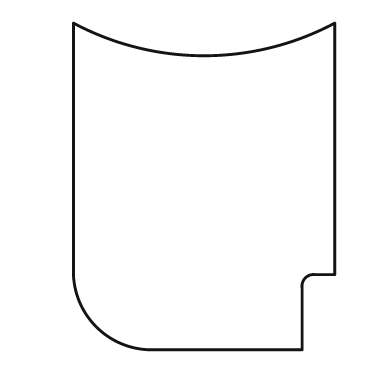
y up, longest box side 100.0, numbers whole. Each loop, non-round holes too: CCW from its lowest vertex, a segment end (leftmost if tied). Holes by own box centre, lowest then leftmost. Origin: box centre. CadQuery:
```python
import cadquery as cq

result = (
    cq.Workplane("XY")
    .moveTo(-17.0, -50.0)
    .lineTo(30.0, -50.0)
    .lineTo(30.0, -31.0)
    .threePointArc((31.0, -28.0), (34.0, -27.0))
    .lineTo(40.0, -27.0)
    .lineTo(40.0, 50.0)
    .threePointArc((0.0, 40.0), (-40.0, 50.0))
    .lineTo(-40.0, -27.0)
    .threePointArc((-33.0, -43.0), (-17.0, -50.0))
    .close()
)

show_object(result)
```